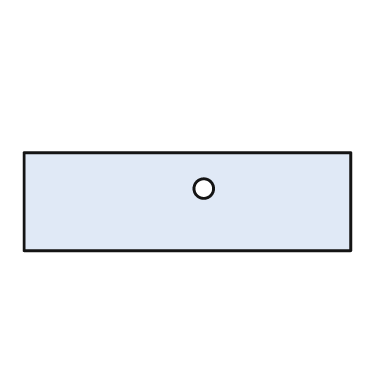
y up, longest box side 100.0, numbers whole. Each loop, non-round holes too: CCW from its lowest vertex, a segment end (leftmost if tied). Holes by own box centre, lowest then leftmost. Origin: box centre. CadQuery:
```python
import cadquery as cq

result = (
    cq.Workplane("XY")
    .moveTo(-50.0, -15.0)
    .lineTo(50.0, -15.0)
    .lineTo(50.0, 15.0)
    .lineTo(-50.0, 15.0)
    .close()
    .moveTo(5.0, 4.0)
    .circle(3.0)
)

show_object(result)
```